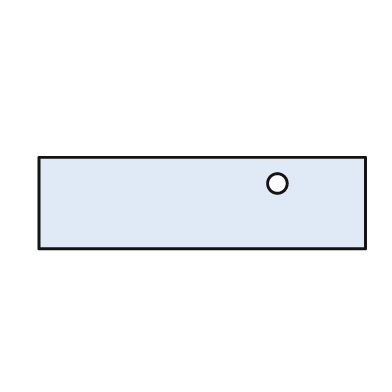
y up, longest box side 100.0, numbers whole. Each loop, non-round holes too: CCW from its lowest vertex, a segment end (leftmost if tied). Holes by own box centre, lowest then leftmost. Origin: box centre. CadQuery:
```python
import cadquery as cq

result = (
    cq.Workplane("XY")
    .moveTo(-50.0, -14.0)
    .lineTo(50.0, -14.0)
    .lineTo(50.0, 14.0)
    .lineTo(-50.0, 14.0)
    .close()
    .moveTo(23.0, 6.0)
    .circle(3.0)
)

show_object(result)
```